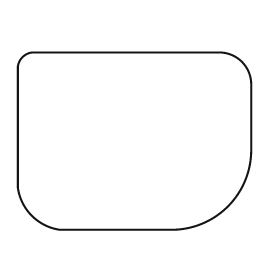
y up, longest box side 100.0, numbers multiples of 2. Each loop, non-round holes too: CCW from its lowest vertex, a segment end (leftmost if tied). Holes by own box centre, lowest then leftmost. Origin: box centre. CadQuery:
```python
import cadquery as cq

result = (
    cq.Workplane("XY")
    .moveTo(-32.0, -38.0)
    .lineTo(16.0, -38.0)
    .threePointArc((40.0, -28.0), (50.0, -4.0))
    .lineTo(50.0, 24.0)
    .threePointArc((46.0, 34.0), (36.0, 38.0))
    .lineTo(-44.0, 38.0)
    .threePointArc((-48.0, 36.0), (-50.0, 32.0))
    .lineTo(-50.0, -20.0)
    .threePointArc((-44.0, -32.0), (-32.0, -38.0))
    .close()
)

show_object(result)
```